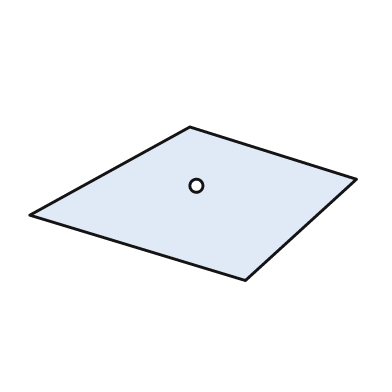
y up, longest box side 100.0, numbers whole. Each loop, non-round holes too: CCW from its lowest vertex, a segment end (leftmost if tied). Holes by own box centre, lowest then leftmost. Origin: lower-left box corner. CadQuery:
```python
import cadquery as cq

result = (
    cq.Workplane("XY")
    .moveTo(66.0, 0.0)
    .lineTo(100.0, 31.0)
    .lineTo(49.0, 47.0)
    .lineTo(0.0, 20.0)
    .close()
    .moveTo(51.0, 29.0)
    .circle(2.0)
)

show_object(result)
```